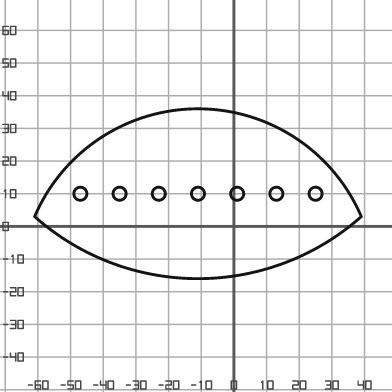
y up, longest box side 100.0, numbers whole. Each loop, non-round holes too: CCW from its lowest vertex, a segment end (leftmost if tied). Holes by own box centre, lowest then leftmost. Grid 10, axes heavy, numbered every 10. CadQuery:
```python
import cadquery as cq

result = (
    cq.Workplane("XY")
    .moveTo(-61.0, 3.0)
    .threePointArc((-11.0, -16.0), (39.0, 3.0))
    .threePointArc((-11.0, 36.0), (-61.0, 3.0))
    .close()
    .moveTo(-47.0, 10.0)
    .circle(2.0)
    .moveTo(-35.0, 10.0)
    .circle(2.0)
    .moveTo(-23.0, 10.0)
    .circle(2.0)
    .moveTo(-11.0, 10.0)
    .circle(2.0)
    .moveTo(1.0, 10.0)
    .circle(2.0)
    .moveTo(13.0, 10.0)
    .circle(2.0)
    .moveTo(25.0, 10.0)
    .circle(2.0)
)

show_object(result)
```